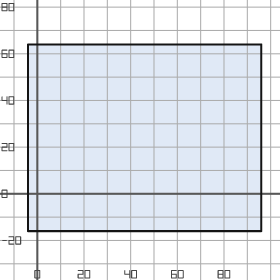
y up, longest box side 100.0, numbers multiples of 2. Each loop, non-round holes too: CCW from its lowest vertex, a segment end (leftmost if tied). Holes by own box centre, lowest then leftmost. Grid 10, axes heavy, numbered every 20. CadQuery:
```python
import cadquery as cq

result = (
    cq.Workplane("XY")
    .moveTo(-4.0, -16.0)
    .lineTo(96.0, -16.0)
    .lineTo(96.0, 64.0)
    .lineTo(-4.0, 64.0)
    .close()
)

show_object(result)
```